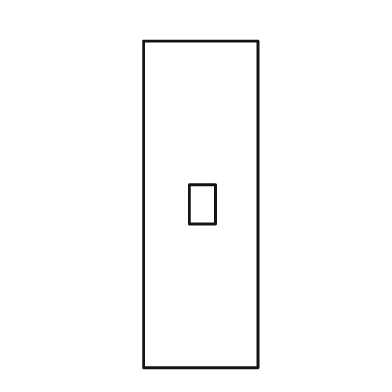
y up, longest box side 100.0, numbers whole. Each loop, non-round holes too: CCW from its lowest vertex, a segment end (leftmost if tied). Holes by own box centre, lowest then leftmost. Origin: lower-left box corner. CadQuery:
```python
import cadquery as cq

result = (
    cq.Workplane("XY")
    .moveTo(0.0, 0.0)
    .lineTo(35.0, 0.0)
    .lineTo(35.0, 100.0)
    .lineTo(0.0, 100.0)
    .close()
    .moveTo(14.0, 44.0)
    .lineTo(22.0, 44.0)
    .lineTo(22.0, 56.0)
    .lineTo(14.0, 56.0)
    .close()
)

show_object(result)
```